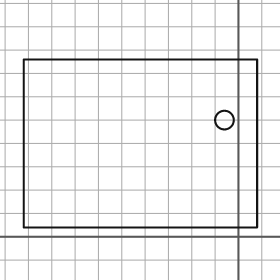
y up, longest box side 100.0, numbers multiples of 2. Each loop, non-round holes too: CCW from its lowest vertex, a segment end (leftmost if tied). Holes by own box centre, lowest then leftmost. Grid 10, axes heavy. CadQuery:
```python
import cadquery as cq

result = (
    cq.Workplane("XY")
    .moveTo(-92.0, 4.0)
    .lineTo(8.0, 4.0)
    .lineTo(8.0, 76.0)
    .lineTo(-92.0, 76.0)
    .close()
    .moveTo(-6.0, 50.0)
    .circle(4.0)
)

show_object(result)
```